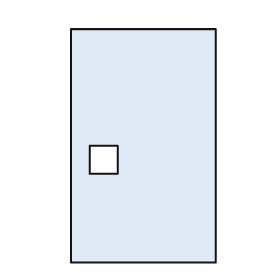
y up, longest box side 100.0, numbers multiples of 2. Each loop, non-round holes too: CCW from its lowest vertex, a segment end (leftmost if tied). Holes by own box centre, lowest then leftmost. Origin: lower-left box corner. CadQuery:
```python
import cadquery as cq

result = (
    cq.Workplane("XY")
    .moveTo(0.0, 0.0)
    .lineTo(62.0, 0.0)
    .lineTo(62.0, 100.0)
    .lineTo(0.0, 100.0)
    .close()
    .moveTo(8.0, 38.0)
    .lineTo(20.0, 38.0)
    .lineTo(20.0, 50.0)
    .lineTo(8.0, 50.0)
    .close()
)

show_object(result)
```